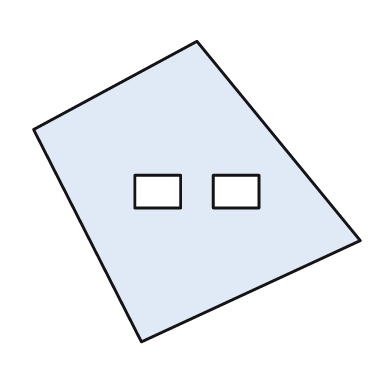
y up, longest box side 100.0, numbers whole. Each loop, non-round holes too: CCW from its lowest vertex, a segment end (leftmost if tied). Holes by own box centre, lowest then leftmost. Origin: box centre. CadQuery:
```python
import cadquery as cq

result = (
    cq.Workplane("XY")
    .moveTo(-17.0, -46.0)
    .lineTo(50.0, -15.0)
    .lineTo(0.0, 46.0)
    .lineTo(-50.0, 19.0)
    .close()
    .moveTo(-19.0, -5.0)
    .lineTo(-5.0, -5.0)
    .lineTo(-5.0, 5.0)
    .lineTo(-19.0, 5.0)
    .close()
    .moveTo(5.0, -5.0)
    .lineTo(19.0, -5.0)
    .lineTo(19.0, 5.0)
    .lineTo(5.0, 5.0)
    .close()
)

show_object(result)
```